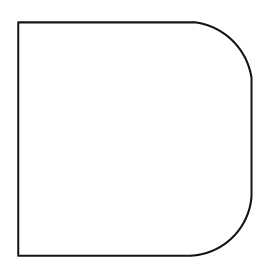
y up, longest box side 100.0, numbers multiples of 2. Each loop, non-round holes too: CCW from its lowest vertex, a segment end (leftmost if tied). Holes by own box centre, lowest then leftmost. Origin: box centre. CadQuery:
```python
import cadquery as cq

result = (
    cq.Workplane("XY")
    .moveTo(-50.0, -50.0)
    .lineTo(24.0, -50.0)
    .threePointArc((42.0, -42.0), (50.0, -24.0))
    .lineTo(50.0, 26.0)
    .threePointArc((42.0, 42.0), (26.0, 50.0))
    .lineTo(-50.0, 50.0)
    .close()
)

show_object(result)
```